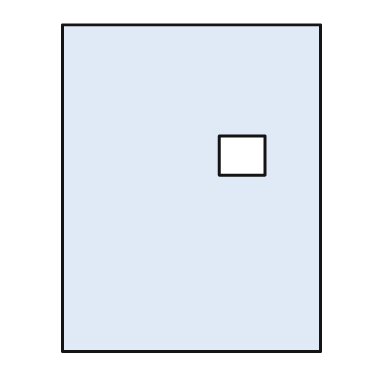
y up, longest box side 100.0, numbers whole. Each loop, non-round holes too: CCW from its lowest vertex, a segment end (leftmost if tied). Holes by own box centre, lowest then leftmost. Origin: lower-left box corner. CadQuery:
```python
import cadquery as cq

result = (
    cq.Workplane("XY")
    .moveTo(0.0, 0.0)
    .lineTo(79.0, 0.0)
    .lineTo(79.0, 100.0)
    .lineTo(0.0, 100.0)
    .close()
    .moveTo(48.0, 54.0)
    .lineTo(62.0, 54.0)
    .lineTo(62.0, 66.0)
    .lineTo(48.0, 66.0)
    .close()
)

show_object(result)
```